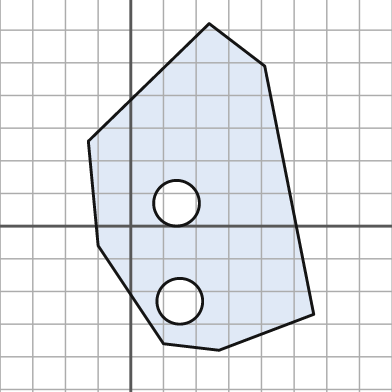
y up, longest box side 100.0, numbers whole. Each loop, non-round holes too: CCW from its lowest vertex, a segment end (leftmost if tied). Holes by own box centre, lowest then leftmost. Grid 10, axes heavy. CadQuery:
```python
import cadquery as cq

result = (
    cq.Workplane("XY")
    .moveTo(27.0, -38.0)
    .lineTo(56.0, -27.0)
    .lineTo(41.0, 49.0)
    .lineTo(24.0, 62.0)
    .lineTo(-13.0, 26.0)
    .lineTo(-10.0, -6.0)
    .lineTo(10.0, -36.0)
    .close()
    .moveTo(15.0, -23.0)
    .circle(7.0)
    .moveTo(14.0, 7.0)
    .circle(7.0)
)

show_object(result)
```